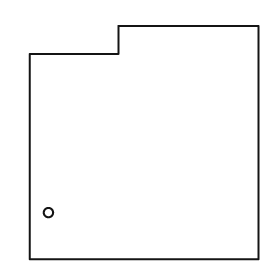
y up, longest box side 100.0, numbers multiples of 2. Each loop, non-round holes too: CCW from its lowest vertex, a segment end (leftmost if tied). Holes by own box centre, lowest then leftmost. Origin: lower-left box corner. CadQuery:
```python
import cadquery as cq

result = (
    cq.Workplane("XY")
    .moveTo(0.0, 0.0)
    .lineTo(98.0, 0.0)
    .lineTo(98.0, 100.0)
    .lineTo(38.0, 100.0)
    .lineTo(38.0, 88.0)
    .lineTo(0.0, 88.0)
    .close()
    .moveTo(8.0, 20.0)
    .circle(2.0)
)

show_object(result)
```